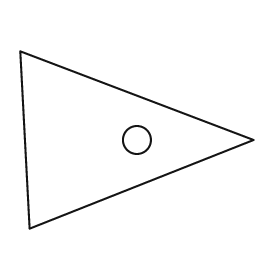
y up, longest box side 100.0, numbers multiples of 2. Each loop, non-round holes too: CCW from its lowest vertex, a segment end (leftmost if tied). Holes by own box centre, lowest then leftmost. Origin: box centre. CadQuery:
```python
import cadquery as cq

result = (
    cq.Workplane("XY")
    .moveTo(-46.0, -38.0)
    .lineTo(50.0, 0.0)
    .lineTo(-50.0, 38.0)
    .close()
    .moveTo(0.0, 0.0)
    .circle(6.0)
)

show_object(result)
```